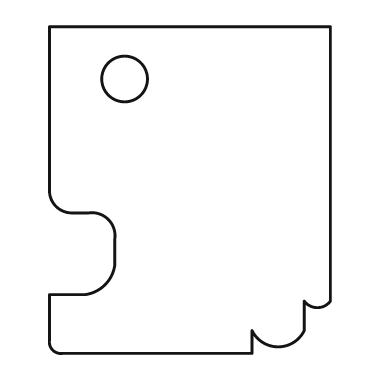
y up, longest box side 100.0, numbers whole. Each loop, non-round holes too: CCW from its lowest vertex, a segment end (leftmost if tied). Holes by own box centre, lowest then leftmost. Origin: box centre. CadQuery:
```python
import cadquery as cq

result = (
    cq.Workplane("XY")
    .moveTo(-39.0, -50.0)
    .lineTo(19.0, -50.0)
    .lineTo(19.0, -43.0)
    .threePointArc((27.0, -48.0), (35.0, -43.0))
    .lineTo(35.0, -34.0)
    .threePointArc((39.0, -36.0), (43.0, -34.0))
    .lineTo(43.0, 50.0)
    .lineTo(-43.0, 50.0)
    .lineTo(-43.0, 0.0)
    .threePointArc((-41.0, -5.0), (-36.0, -7.0))
    .lineTo(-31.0, -7.0)
    .threePointArc((-25.0, -9.0), (-23.0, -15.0))
    .lineTo(-23.0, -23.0)
    .threePointArc((-26.0, -29.0), (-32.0, -32.0))
    .lineTo(-43.0, -32.0)
    .lineTo(-43.0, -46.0)
    .threePointArc((-42.0, -49.0), (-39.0, -50.0))
    .close()
    .moveTo(-20.0, 34.0)
    .circle(7.0)
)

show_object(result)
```